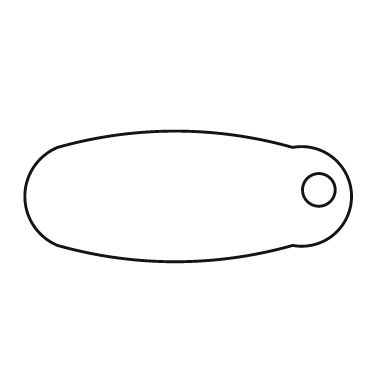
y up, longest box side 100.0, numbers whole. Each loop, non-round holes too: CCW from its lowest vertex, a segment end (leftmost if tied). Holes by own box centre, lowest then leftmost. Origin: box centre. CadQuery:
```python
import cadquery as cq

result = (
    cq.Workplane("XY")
    .moveTo(-40.0, -15.0)
    .threePointArc((-4.0, -20.0), (32.0, -15.0))
    .threePointArc((50.0, 0.0), (32.0, 15.0))
    .threePointArc((-4.0, 20.0), (-40.0, 15.0))
    .threePointArc((-50.0, 0.0), (-40.0, -15.0))
    .close()
    .moveTo(40.0, 2.0)
    .circle(5.0)
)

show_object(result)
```